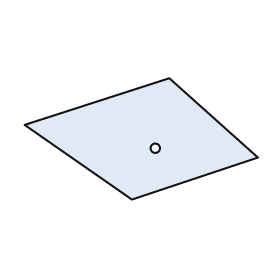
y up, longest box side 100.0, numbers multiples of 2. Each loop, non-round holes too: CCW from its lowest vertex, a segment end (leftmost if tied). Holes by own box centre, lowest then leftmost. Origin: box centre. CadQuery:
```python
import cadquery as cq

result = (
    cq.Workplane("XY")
    .moveTo(-4.0, -26.0)
    .lineTo(50.0, -8.0)
    .lineTo(12.0, 26.0)
    .lineTo(-50.0, 6.0)
    .close()
    .moveTo(6.0, -4.0)
    .circle(2.0)
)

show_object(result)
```